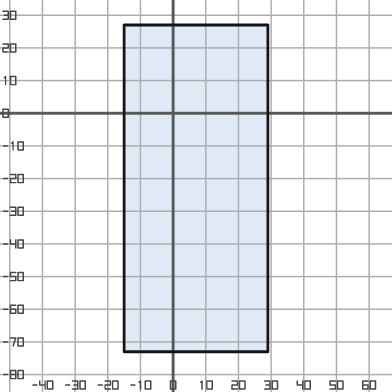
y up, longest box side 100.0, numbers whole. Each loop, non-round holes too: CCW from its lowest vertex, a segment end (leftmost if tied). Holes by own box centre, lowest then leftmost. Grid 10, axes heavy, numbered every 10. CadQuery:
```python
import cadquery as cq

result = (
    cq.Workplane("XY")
    .moveTo(-15.0, -73.0)
    .lineTo(29.0, -73.0)
    .lineTo(29.0, 27.0)
    .lineTo(-15.0, 27.0)
    .close()
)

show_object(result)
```